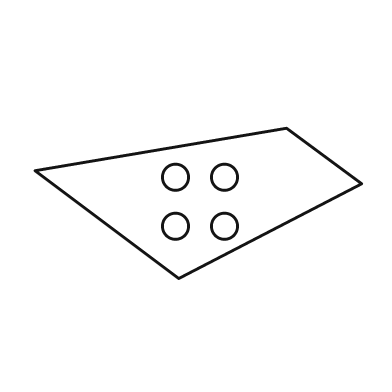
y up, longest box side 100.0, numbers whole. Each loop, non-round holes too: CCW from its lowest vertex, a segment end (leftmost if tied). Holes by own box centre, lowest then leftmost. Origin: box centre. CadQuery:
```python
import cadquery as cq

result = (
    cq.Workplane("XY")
    .moveTo(-6.0, -23.0)
    .lineTo(50.0, 6.0)
    .lineTo(27.0, 23.0)
    .lineTo(-50.0, 10.0)
    .close()
    .moveTo(-7.0, -7.0)
    .circle(4.0)
    .moveTo(8.0, -7.0)
    .circle(4.0)
    .moveTo(-7.0, 8.0)
    .circle(4.0)
    .moveTo(8.0, 8.0)
    .circle(4.0)
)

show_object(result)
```